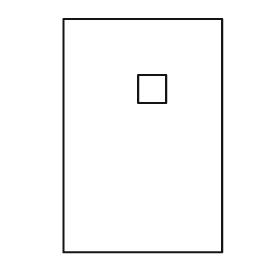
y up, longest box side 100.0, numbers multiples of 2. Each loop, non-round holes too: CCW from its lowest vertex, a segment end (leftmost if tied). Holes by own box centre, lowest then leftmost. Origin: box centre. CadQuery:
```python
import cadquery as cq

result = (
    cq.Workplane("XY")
    .moveTo(-34.0, -50.0)
    .lineTo(34.0, -50.0)
    .lineTo(34.0, 50.0)
    .lineTo(-34.0, 50.0)
    .close()
    .moveTo(-2.0, 14.0)
    .lineTo(10.0, 14.0)
    .lineTo(10.0, 26.0)
    .lineTo(-2.0, 26.0)
    .close()
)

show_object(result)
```